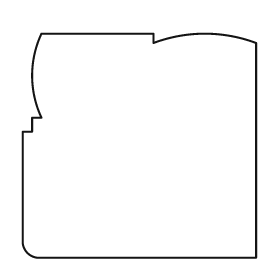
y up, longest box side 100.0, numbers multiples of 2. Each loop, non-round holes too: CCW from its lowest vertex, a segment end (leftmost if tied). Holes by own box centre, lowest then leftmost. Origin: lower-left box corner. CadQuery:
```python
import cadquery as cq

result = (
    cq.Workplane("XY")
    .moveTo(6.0, 0.0)
    .lineTo(100.0, 0.0)
    .lineTo(100.0, 92.0)
    .threePointArc((78.0, 96.0), (56.0, 92.0))
    .lineTo(56.0, 96.0)
    .lineTo(8.0, 96.0)
    .threePointArc((4.0, 78.0), (8.0, 60.0))
    .lineTo(4.0, 60.0)
    .lineTo(4.0, 54.0)
    .lineTo(0.0, 54.0)
    .lineTo(0.0, 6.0)
    .threePointArc((2.0, 2.0), (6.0, 0.0))
    .close()
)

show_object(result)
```